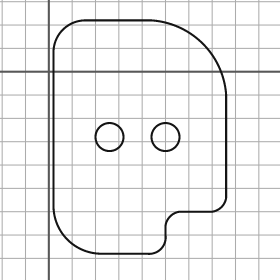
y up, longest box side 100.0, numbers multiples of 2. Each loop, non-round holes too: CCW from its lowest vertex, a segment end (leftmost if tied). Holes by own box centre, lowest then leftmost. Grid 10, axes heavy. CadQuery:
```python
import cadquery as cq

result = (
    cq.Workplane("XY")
    .moveTo(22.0, -78.0)
    .lineTo(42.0, -78.0)
    .threePointArc((48.0, -76.0), (50.0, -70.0))
    .lineTo(50.0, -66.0)
    .threePointArc((52.0, -62.0), (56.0, -60.0))
    .lineTo(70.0, -60.0)
    .threePointArc((74.0, -58.0), (76.0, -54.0))
    .lineTo(76.0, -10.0)
    .threePointArc((66.0, 12.0), (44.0, 22.0))
    .lineTo(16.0, 22.0)
    .threePointArc((6.0, 18.0), (2.0, 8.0))
    .lineTo(2.0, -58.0)
    .threePointArc((8.0, -72.0), (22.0, -78.0))
    .close()
    .moveTo(26.0, -28.0)
    .circle(6.0)
    .moveTo(50.0, -28.0)
    .circle(6.0)
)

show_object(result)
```